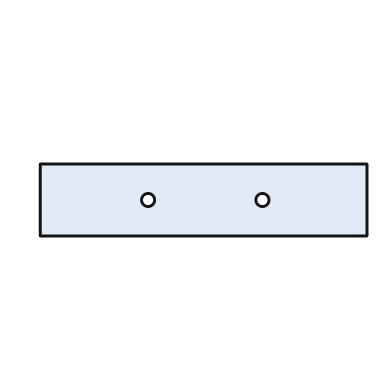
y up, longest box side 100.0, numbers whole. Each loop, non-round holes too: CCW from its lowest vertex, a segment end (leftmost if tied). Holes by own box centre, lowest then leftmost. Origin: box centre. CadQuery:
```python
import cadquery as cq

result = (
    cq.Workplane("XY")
    .moveTo(-50.0, -11.0)
    .lineTo(50.0, -11.0)
    .lineTo(50.0, 11.0)
    .lineTo(-50.0, 11.0)
    .close()
    .moveTo(-17.0, 0.0)
    .circle(2.0)
    .moveTo(18.0, 0.0)
    .circle(2.0)
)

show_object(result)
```